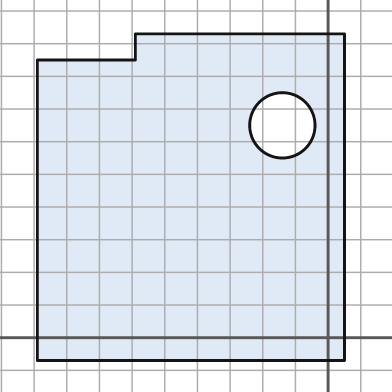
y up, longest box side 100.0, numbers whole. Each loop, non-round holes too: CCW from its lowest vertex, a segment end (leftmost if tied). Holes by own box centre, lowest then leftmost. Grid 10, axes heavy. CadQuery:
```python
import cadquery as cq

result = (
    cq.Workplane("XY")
    .moveTo(-89.0, -7.0)
    .lineTo(5.0, -7.0)
    .lineTo(5.0, 93.0)
    .lineTo(-59.0, 93.0)
    .lineTo(-59.0, 85.0)
    .lineTo(-89.0, 85.0)
    .close()
    .moveTo(-14.0, 65.0)
    .circle(10.0)
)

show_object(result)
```